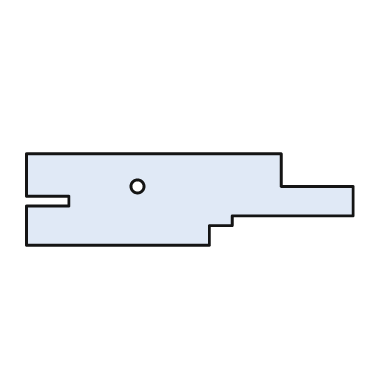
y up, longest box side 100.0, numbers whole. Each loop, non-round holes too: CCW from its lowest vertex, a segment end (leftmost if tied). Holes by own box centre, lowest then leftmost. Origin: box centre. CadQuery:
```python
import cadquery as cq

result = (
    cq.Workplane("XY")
    .moveTo(-50.0, -14.0)
    .lineTo(6.0, -14.0)
    .lineTo(6.0, -8.0)
    .lineTo(13.0, -8.0)
    .lineTo(13.0, -5.0)
    .lineTo(50.0, -5.0)
    .lineTo(50.0, 4.0)
    .lineTo(28.0, 4.0)
    .lineTo(28.0, 14.0)
    .lineTo(-50.0, 14.0)
    .lineTo(-50.0, 1.0)
    .lineTo(-37.0, 1.0)
    .lineTo(-37.0, -2.0)
    .lineTo(-50.0, -2.0)
    .close()
    .moveTo(-16.0, 4.0)
    .circle(2.0)
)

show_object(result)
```